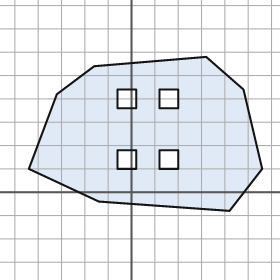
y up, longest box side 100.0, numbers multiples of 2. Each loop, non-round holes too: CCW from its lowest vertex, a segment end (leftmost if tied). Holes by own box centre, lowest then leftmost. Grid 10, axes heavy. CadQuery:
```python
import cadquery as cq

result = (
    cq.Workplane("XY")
    .moveTo(42.0, -8.0)
    .lineTo(56.0, 10.0)
    .lineTo(48.0, 44.0)
    .lineTo(32.0, 58.0)
    .lineTo(-16.0, 54.0)
    .lineTo(-32.0, 42.0)
    .lineTo(-44.0, 10.0)
    .lineTo(-14.0, -4.0)
    .close()
    .moveTo(-6.0, 10.0)
    .lineTo(2.0, 10.0)
    .lineTo(2.0, 18.0)
    .lineTo(-6.0, 18.0)
    .close()
    .moveTo(12.0, 10.0)
    .lineTo(20.0, 10.0)
    .lineTo(20.0, 18.0)
    .lineTo(12.0, 18.0)
    .close()
    .moveTo(-6.0, 36.0)
    .lineTo(2.0, 36.0)
    .lineTo(2.0, 44.0)
    .lineTo(-6.0, 44.0)
    .close()
    .moveTo(12.0, 36.0)
    .lineTo(20.0, 36.0)
    .lineTo(20.0, 44.0)
    .lineTo(12.0, 44.0)
    .close()
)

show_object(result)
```